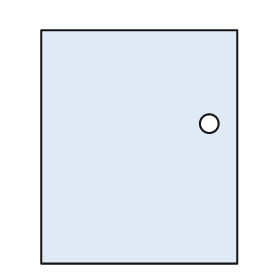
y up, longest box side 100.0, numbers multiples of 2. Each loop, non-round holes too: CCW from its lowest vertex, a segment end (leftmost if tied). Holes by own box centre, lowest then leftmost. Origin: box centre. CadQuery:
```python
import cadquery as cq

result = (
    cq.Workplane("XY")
    .moveTo(-42.0, -50.0)
    .lineTo(42.0, -50.0)
    .lineTo(42.0, 50.0)
    .lineTo(-42.0, 50.0)
    .close()
    .moveTo(30.0, 10.0)
    .circle(4.0)
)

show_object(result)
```